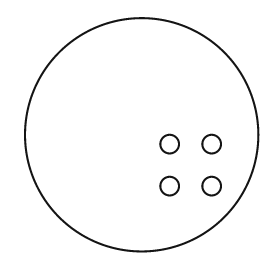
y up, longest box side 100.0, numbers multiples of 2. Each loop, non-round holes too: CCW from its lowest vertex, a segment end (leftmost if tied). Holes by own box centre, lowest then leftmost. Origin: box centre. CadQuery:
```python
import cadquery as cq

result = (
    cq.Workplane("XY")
    .moveTo(0.0, 0.0)
    .circle(50.0)
    .moveTo(12.0, -22.0)
    .circle(4.0)
    .moveTo(30.0, -22.0)
    .circle(4.0)
    .moveTo(12.0, -4.0)
    .circle(4.0)
    .moveTo(30.0, -4.0)
    .circle(4.0)
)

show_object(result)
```